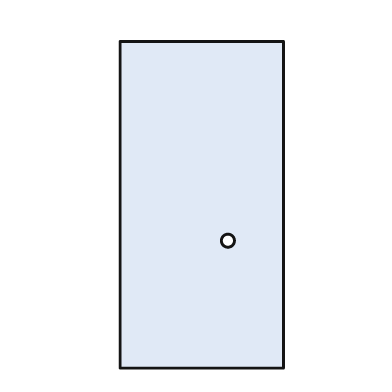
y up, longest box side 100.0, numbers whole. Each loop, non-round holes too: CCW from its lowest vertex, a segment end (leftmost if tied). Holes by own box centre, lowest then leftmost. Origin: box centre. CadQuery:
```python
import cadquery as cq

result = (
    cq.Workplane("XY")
    .moveTo(-25.0, -50.0)
    .lineTo(25.0, -50.0)
    .lineTo(25.0, 50.0)
    .lineTo(-25.0, 50.0)
    .close()
    .moveTo(8.0, -11.0)
    .circle(2.0)
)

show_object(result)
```